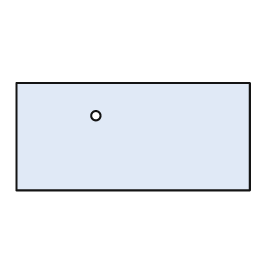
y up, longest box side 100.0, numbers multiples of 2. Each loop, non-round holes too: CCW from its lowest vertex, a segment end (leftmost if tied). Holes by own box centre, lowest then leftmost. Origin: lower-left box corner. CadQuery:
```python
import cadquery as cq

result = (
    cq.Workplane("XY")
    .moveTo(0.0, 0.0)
    .lineTo(100.0, 0.0)
    .lineTo(100.0, 46.0)
    .lineTo(0.0, 46.0)
    .close()
    .moveTo(34.0, 32.0)
    .circle(2.0)
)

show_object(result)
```